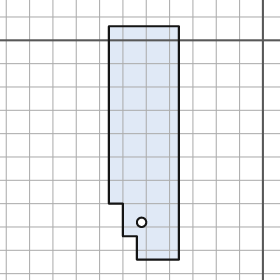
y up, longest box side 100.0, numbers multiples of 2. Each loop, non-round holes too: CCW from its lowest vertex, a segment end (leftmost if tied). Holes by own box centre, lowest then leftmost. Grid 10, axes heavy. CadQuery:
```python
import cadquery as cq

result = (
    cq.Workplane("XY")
    .moveTo(-54.0, -94.0)
    .lineTo(-36.0, -94.0)
    .lineTo(-36.0, 6.0)
    .lineTo(-66.0, 6.0)
    .lineTo(-66.0, -70.0)
    .lineTo(-60.0, -70.0)
    .lineTo(-60.0, -84.0)
    .lineTo(-54.0, -84.0)
    .close()
    .moveTo(-52.0, -78.0)
    .circle(2.0)
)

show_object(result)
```